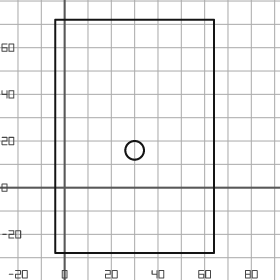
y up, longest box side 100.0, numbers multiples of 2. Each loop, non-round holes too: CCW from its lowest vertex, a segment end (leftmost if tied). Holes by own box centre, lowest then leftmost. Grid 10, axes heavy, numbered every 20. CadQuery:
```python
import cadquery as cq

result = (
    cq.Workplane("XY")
    .moveTo(-4.0, -28.0)
    .lineTo(64.0, -28.0)
    .lineTo(64.0, 72.0)
    .lineTo(-4.0, 72.0)
    .close()
    .moveTo(30.0, 16.0)
    .circle(4.0)
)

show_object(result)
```